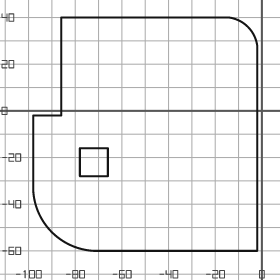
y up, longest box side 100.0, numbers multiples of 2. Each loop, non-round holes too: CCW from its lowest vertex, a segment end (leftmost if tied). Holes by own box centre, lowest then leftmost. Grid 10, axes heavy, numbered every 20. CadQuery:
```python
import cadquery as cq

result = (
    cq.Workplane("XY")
    .moveTo(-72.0, -60.0)
    .lineTo(-2.0, -60.0)
    .lineTo(-2.0, 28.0)
    .threePointArc((-6.0, 36.0), (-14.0, 40.0))
    .lineTo(-86.0, 40.0)
    .lineTo(-86.0, -2.0)
    .lineTo(-98.0, -2.0)
    .lineTo(-98.0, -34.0)
    .threePointArc((-90.0, -52.0), (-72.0, -60.0))
    .close()
    .moveTo(-78.0, -28.0)
    .lineTo(-66.0, -28.0)
    .lineTo(-66.0, -16.0)
    .lineTo(-78.0, -16.0)
    .close()
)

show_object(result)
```